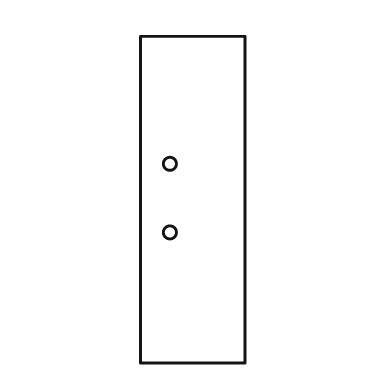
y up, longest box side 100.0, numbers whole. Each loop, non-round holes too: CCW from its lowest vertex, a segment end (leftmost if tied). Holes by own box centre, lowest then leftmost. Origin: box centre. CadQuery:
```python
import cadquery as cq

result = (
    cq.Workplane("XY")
    .moveTo(-16.0, -50.0)
    .lineTo(16.0, -50.0)
    .lineTo(16.0, 50.0)
    .lineTo(-16.0, 50.0)
    .close()
    .moveTo(-7.0, -10.0)
    .circle(2.0)
    .moveTo(-7.0, 11.0)
    .circle(2.0)
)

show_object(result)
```